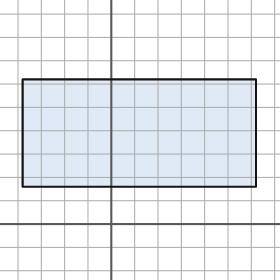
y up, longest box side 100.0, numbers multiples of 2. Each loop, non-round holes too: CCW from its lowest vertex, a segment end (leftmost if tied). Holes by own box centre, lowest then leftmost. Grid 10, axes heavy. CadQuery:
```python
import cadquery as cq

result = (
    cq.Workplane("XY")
    .moveTo(-38.0, 16.0)
    .lineTo(62.0, 16.0)
    .lineTo(62.0, 62.0)
    .lineTo(-38.0, 62.0)
    .close()
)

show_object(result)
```